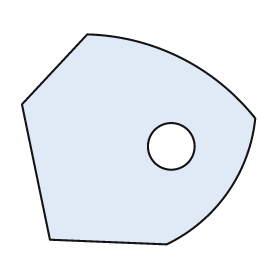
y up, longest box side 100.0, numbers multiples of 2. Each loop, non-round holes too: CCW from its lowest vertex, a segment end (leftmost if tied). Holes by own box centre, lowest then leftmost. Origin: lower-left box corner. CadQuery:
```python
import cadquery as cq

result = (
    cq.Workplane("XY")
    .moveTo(62.0, 0.0)
    .threePointArc((88.0, 22.0), (100.0, 54.0))
    .threePointArc((68.0, 80.0), (28.0, 90.0))
    .lineTo(0.0, 60.0)
    .lineTo(12.0, 2.0)
    .close()
    .moveTo(64.0, 42.0)
    .circle(10.0)
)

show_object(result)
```